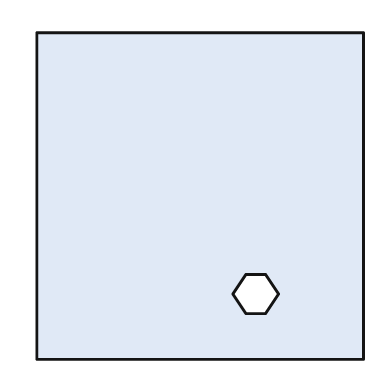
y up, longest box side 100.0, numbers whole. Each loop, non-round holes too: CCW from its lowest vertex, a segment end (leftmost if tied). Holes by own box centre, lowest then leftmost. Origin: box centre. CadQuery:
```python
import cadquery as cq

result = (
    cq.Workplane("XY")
    .moveTo(-50.0, -50.0)
    .lineTo(50.0, -50.0)
    .lineTo(50.0, 50.0)
    .lineTo(-50.0, 50.0)
    .close()
    .moveTo(14.0, -36.0)
    .lineTo(20.0, -36.0)
    .lineTo(24.0, -30.0)
    .lineTo(20.0, -24.0)
    .lineTo(14.0, -24.0)
    .lineTo(10.0, -30.0)
    .close()
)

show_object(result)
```